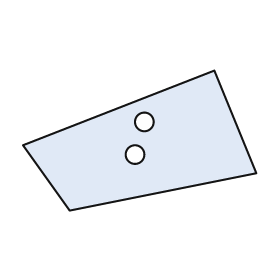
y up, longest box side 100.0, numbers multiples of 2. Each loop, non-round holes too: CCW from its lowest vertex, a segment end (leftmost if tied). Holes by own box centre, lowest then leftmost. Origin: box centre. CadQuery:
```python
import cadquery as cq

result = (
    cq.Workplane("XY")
    .moveTo(-30.0, -30.0)
    .lineTo(50.0, -14.0)
    .lineTo(32.0, 30.0)
    .lineTo(-50.0, -2.0)
    .close()
    .moveTo(-2.0, -6.0)
    .circle(4.0)
    .moveTo(2.0, 8.0)
    .circle(4.0)
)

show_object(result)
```